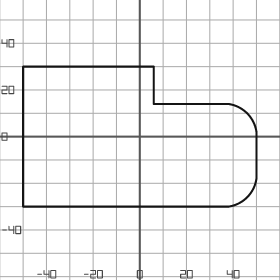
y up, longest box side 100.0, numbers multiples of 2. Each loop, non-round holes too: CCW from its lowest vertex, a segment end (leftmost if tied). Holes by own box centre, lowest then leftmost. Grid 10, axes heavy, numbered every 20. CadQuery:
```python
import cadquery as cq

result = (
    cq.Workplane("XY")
    .moveTo(-50.0, -30.0)
    .lineTo(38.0, -30.0)
    .threePointArc((46.0, -26.0), (50.0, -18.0))
    .lineTo(50.0, 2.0)
    .threePointArc((46.0, 10.0), (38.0, 14.0))
    .lineTo(6.0, 14.0)
    .lineTo(6.0, 30.0)
    .lineTo(-50.0, 30.0)
    .close()
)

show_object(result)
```